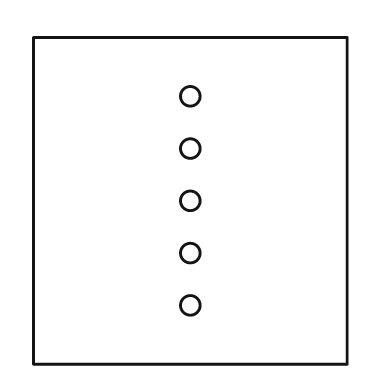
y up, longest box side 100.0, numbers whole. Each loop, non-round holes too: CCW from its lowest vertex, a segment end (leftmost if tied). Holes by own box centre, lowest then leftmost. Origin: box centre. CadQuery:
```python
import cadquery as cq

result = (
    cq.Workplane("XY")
    .moveTo(-48.0, -50.0)
    .lineTo(48.0, -50.0)
    .lineTo(48.0, 50.0)
    .lineTo(-48.0, 50.0)
    .close()
    .moveTo(0.0, -32.0)
    .circle(3.0)
    .moveTo(0.0, -16.0)
    .circle(3.0)
    .moveTo(0.0, 0.0)
    .circle(3.0)
    .moveTo(0.0, 16.0)
    .circle(3.0)
    .moveTo(0.0, 32.0)
    .circle(3.0)
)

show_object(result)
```